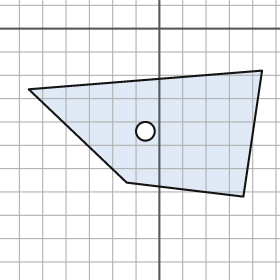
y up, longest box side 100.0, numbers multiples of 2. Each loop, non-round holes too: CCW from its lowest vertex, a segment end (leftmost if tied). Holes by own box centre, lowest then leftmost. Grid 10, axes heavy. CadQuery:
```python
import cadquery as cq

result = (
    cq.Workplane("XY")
    .moveTo(36.0, -72.0)
    .lineTo(44.0, -18.0)
    .lineTo(-56.0, -26.0)
    .lineTo(-14.0, -66.0)
    .close()
    .moveTo(-6.0, -44.0)
    .circle(4.0)
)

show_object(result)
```